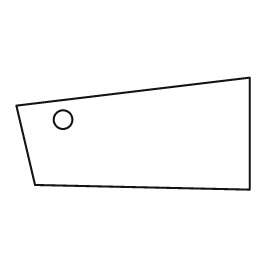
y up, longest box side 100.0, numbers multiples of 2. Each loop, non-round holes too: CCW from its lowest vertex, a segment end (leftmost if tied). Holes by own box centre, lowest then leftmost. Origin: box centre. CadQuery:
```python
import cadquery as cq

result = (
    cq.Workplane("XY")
    .moveTo(50.0, -24.0)
    .lineTo(50.0, 24.0)
    .lineTo(-50.0, 12.0)
    .lineTo(-42.0, -22.0)
    .close()
    .moveTo(-30.0, 6.0)
    .circle(4.0)
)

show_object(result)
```